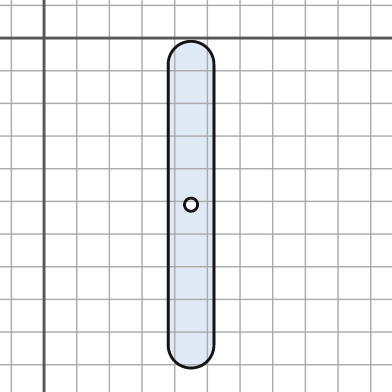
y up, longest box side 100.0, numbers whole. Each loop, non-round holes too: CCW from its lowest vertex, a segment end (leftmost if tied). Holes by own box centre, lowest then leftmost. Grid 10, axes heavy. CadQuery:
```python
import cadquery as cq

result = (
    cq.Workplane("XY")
    .moveTo(38.0, -94.0)
    .threePointArc((45.0, -101.0), (52.0, -94.0))
    .lineTo(52.0, -8.0)
    .threePointArc((45.0, -1.0), (38.0, -8.0))
    .close()
    .moveTo(45.0, -51.0)
    .circle(2.0)
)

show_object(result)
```